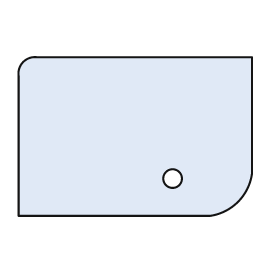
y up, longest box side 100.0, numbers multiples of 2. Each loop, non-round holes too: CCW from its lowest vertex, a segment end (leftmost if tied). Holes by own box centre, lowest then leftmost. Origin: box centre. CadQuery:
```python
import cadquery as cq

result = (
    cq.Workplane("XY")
    .moveTo(-50.0, -34.0)
    .lineTo(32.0, -34.0)
    .threePointArc((44.0, -28.0), (50.0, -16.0))
    .lineTo(50.0, 34.0)
    .lineTo(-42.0, 34.0)
    .threePointArc((-48.0, 32.0), (-50.0, 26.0))
    .close()
    .moveTo(16.0, -18.0)
    .circle(4.0)
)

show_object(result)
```